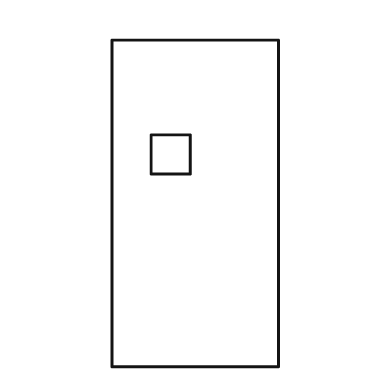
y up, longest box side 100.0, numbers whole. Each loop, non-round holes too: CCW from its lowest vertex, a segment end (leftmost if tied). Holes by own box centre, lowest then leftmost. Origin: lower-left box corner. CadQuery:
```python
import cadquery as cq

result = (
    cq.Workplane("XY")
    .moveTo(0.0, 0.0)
    .lineTo(51.0, 0.0)
    .lineTo(51.0, 100.0)
    .lineTo(0.0, 100.0)
    .close()
    .moveTo(12.0, 59.0)
    .lineTo(24.0, 59.0)
    .lineTo(24.0, 71.0)
    .lineTo(12.0, 71.0)
    .close()
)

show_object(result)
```